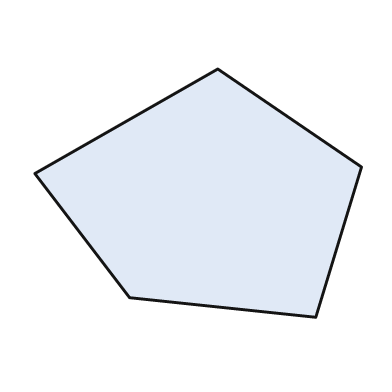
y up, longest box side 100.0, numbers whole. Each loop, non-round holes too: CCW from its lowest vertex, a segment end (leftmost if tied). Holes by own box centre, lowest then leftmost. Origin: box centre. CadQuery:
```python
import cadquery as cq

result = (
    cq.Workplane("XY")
    .moveTo(36.0, -38.0)
    .lineTo(50.0, 8.0)
    .lineTo(6.0, 38.0)
    .lineTo(-50.0, 6.0)
    .lineTo(-21.0, -32.0)
    .close()
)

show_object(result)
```